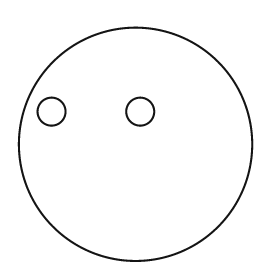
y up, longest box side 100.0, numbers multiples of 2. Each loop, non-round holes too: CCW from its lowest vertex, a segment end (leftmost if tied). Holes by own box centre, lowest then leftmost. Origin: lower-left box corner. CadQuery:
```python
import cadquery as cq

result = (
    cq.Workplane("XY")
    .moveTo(50.0, 50.0)
    .circle(50.0)
    .moveTo(14.0, 64.0)
    .circle(6.0)
    .moveTo(52.0, 64.0)
    .circle(6.0)
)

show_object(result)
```